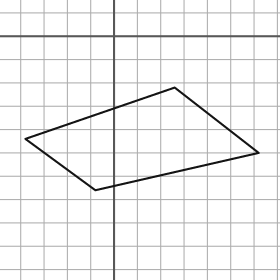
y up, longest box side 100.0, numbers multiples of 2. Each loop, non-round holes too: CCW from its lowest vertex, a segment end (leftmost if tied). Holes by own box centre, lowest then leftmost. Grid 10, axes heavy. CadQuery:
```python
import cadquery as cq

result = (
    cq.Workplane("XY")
    .moveTo(-8.0, -66.0)
    .lineTo(62.0, -50.0)
    .lineTo(26.0, -22.0)
    .lineTo(-38.0, -44.0)
    .close()
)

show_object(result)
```